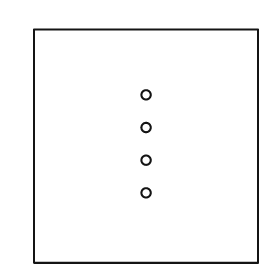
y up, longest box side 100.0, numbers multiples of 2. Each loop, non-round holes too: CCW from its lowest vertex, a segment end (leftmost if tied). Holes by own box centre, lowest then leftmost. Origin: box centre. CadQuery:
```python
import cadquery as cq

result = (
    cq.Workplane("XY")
    .moveTo(-48.0, -50.0)
    .lineTo(48.0, -50.0)
    .lineTo(48.0, 50.0)
    .lineTo(-48.0, 50.0)
    .close()
    .moveTo(0.0, -20.0)
    .circle(2.0)
    .moveTo(0.0, -6.0)
    .circle(2.0)
    .moveTo(0.0, 8.0)
    .circle(2.0)
    .moveTo(0.0, 22.0)
    .circle(2.0)
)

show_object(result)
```